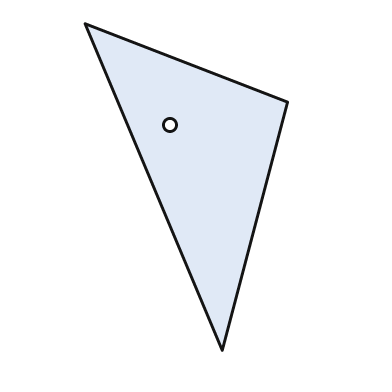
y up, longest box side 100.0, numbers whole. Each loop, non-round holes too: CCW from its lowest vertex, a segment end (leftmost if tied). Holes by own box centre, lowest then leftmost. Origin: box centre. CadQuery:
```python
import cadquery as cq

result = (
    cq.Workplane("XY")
    .moveTo(11.0, -50.0)
    .lineTo(31.0, 26.0)
    .lineTo(-31.0, 50.0)
    .close()
    .moveTo(-5.0, 19.0)
    .circle(2.0)
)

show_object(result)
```